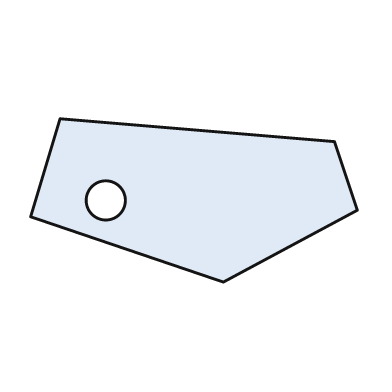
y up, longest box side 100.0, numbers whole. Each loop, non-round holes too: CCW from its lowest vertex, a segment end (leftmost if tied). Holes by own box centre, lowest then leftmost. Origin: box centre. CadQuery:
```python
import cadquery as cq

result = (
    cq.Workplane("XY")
    .moveTo(9.0, -25.0)
    .lineTo(50.0, -3.0)
    .lineTo(43.0, 18.0)
    .lineTo(-41.0, 25.0)
    .lineTo(-50.0, -5.0)
    .close()
    .moveTo(-27.0, 0.0)
    .circle(6.0)
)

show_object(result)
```